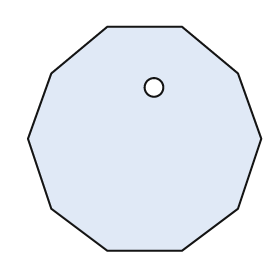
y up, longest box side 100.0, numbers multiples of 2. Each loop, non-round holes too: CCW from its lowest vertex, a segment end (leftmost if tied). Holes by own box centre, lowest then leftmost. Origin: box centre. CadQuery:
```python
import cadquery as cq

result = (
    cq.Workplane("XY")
    .moveTo(-16.0, -48.0)
    .lineTo(16.0, -48.0)
    .lineTo(40.0, -30.0)
    .lineTo(50.0, 0.0)
    .lineTo(40.0, 28.0)
    .lineTo(16.0, 48.0)
    .lineTo(-16.0, 48.0)
    .lineTo(-40.0, 28.0)
    .lineTo(-50.0, 0.0)
    .lineTo(-40.0, -30.0)
    .close()
    .moveTo(4.0, 22.0)
    .circle(4.0)
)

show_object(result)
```